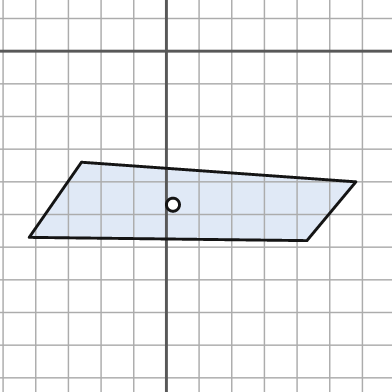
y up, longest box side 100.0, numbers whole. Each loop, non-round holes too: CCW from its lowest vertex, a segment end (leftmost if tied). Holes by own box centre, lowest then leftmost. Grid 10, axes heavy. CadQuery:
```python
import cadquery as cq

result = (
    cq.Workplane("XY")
    .moveTo(43.0, -58.0)
    .lineTo(58.0, -40.0)
    .lineTo(-26.0, -34.0)
    .lineTo(-42.0, -57.0)
    .close()
    .moveTo(2.0, -47.0)
    .circle(2.0)
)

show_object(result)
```